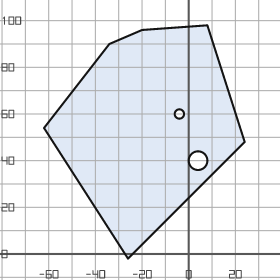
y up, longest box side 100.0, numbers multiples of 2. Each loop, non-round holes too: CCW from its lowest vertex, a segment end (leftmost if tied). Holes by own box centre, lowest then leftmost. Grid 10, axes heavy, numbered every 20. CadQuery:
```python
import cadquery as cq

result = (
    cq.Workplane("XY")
    .moveTo(-26.0, -2.0)
    .lineTo(24.0, 48.0)
    .lineTo(8.0, 98.0)
    .lineTo(-20.0, 96.0)
    .lineTo(-34.0, 90.0)
    .lineTo(-62.0, 54.0)
    .close()
    .moveTo(4.0, 40.0)
    .circle(4.0)
    .moveTo(-4.0, 60.0)
    .circle(2.0)
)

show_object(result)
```